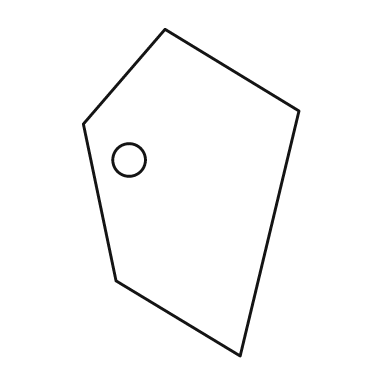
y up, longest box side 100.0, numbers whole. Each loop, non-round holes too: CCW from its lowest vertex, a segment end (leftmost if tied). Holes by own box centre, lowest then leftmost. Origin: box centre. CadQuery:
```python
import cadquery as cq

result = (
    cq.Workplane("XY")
    .moveTo(15.0, -50.0)
    .lineTo(33.0, 25.0)
    .lineTo(-8.0, 50.0)
    .lineTo(-33.0, 21.0)
    .lineTo(-23.0, -27.0)
    .close()
    .moveTo(-19.0, 10.0)
    .circle(5.0)
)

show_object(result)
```